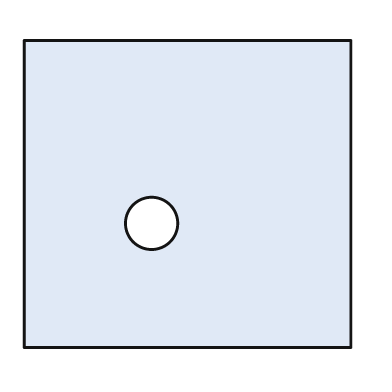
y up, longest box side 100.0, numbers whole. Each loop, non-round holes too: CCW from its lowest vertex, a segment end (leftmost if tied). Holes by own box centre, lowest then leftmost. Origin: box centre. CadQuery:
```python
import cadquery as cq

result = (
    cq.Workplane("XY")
    .moveTo(-50.0, -47.0)
    .lineTo(50.0, -47.0)
    .lineTo(50.0, 47.0)
    .lineTo(-50.0, 47.0)
    .close()
    .moveTo(-11.0, -9.0)
    .circle(8.0)
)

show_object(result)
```